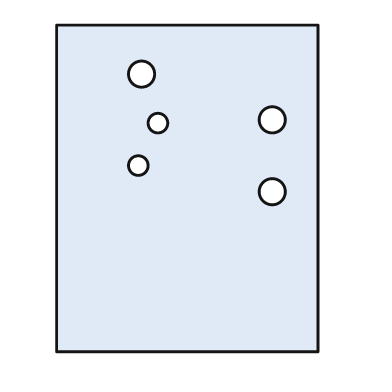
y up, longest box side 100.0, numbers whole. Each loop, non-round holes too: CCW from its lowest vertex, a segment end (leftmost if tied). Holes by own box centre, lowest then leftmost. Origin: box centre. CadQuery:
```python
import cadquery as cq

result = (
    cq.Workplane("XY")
    .moveTo(-40.0, -50.0)
    .lineTo(40.0, -50.0)
    .lineTo(40.0, 50.0)
    .lineTo(-40.0, 50.0)
    .close()
    .moveTo(26.0, -1.0)
    .circle(4.0)
    .moveTo(-15.0, 7.0)
    .circle(3.0)
    .moveTo(-9.0, 20.0)
    .circle(3.0)
    .moveTo(26.0, 21.0)
    .circle(4.0)
    .moveTo(-14.0, 35.0)
    .circle(4.0)
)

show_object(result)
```